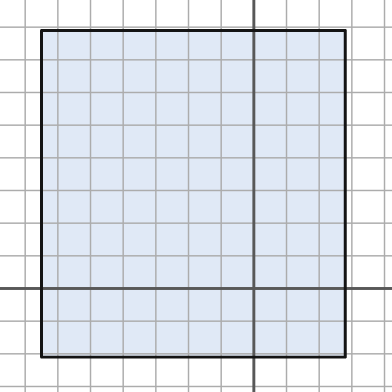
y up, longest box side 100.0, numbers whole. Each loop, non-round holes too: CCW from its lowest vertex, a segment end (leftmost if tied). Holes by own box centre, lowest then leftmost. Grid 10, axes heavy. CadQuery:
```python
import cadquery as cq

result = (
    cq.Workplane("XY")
    .moveTo(-65.0, -21.0)
    .lineTo(28.0, -21.0)
    .lineTo(28.0, 79.0)
    .lineTo(-65.0, 79.0)
    .close()
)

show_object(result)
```